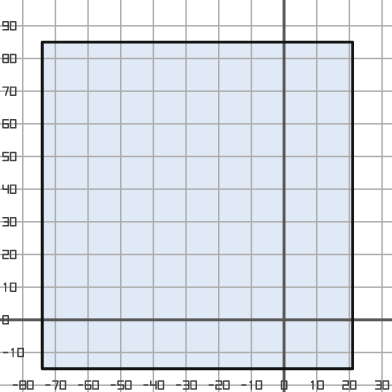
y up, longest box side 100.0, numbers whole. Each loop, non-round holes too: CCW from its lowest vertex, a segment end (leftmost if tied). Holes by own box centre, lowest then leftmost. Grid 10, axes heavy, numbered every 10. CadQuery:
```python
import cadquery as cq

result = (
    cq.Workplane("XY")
    .moveTo(-74.0, -15.0)
    .lineTo(21.0, -15.0)
    .lineTo(21.0, 85.0)
    .lineTo(-74.0, 85.0)
    .close()
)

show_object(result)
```